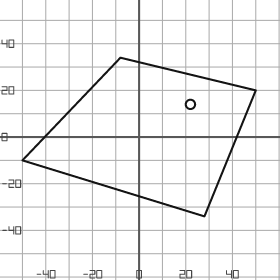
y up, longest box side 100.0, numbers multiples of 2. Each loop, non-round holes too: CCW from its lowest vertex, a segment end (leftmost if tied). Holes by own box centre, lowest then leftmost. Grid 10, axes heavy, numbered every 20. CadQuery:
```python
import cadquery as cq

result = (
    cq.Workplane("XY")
    .moveTo(28.0, -34.0)
    .lineTo(50.0, 20.0)
    .lineTo(-8.0, 34.0)
    .lineTo(-50.0, -10.0)
    .close()
    .moveTo(22.0, 14.0)
    .circle(2.0)
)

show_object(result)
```